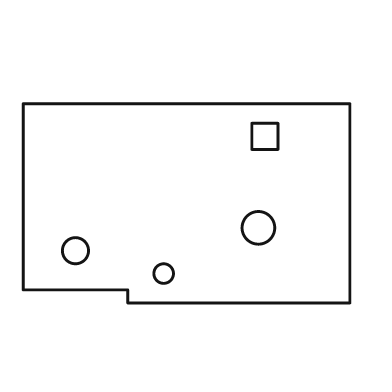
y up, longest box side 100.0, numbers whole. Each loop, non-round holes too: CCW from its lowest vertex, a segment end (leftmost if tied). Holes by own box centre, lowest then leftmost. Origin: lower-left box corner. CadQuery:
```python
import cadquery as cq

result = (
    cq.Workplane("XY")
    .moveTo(32.0, 0.0)
    .lineTo(100.0, 0.0)
    .lineTo(100.0, 61.0)
    .lineTo(0.0, 61.0)
    .lineTo(0.0, 4.0)
    .lineTo(32.0, 4.0)
    .close()
    .moveTo(43.0, 9.0)
    .circle(3.0)
    .moveTo(16.0, 16.0)
    .circle(4.0)
    .moveTo(72.0, 23.0)
    .circle(5.0)
    .moveTo(70.0, 47.0)
    .lineTo(78.0, 47.0)
    .lineTo(78.0, 55.0)
    .lineTo(70.0, 55.0)
    .close()
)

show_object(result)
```